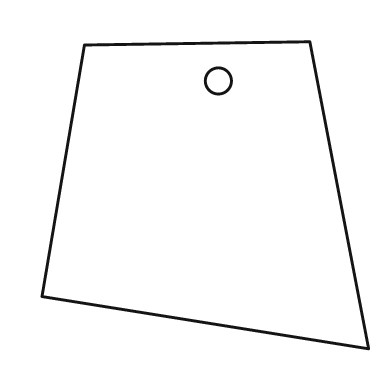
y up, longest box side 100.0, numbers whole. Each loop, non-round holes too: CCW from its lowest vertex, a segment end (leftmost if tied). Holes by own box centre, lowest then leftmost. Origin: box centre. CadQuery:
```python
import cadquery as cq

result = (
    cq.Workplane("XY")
    .moveTo(50.0, -47.0)
    .lineTo(32.0, 47.0)
    .lineTo(-37.0, 46.0)
    .lineTo(-50.0, -31.0)
    .close()
    .moveTo(4.0, 35.0)
    .circle(4.0)
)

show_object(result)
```